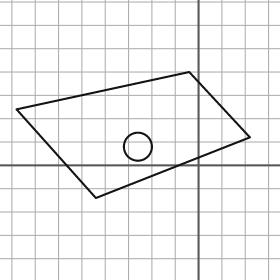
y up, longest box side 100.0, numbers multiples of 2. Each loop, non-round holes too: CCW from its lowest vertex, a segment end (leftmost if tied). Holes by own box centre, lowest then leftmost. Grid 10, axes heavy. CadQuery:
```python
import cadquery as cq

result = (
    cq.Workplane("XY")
    .moveTo(-44.0, -14.0)
    .lineTo(22.0, 12.0)
    .lineTo(-4.0, 40.0)
    .lineTo(-78.0, 24.0)
    .close()
    .moveTo(-26.0, 8.0)
    .circle(6.0)
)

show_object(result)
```